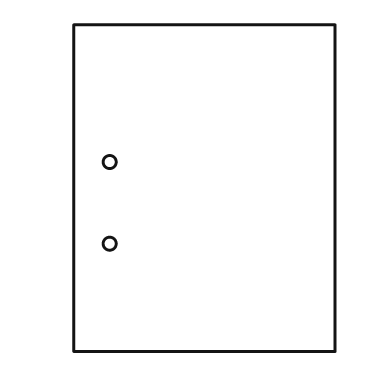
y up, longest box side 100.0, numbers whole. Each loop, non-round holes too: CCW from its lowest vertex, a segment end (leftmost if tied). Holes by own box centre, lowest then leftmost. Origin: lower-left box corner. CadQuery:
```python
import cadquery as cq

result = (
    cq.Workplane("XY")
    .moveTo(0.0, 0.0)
    .lineTo(80.0, 0.0)
    .lineTo(80.0, 100.0)
    .lineTo(0.0, 100.0)
    .close()
    .moveTo(11.0, 33.0)
    .circle(2.0)
    .moveTo(11.0, 58.0)
    .circle(2.0)
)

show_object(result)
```